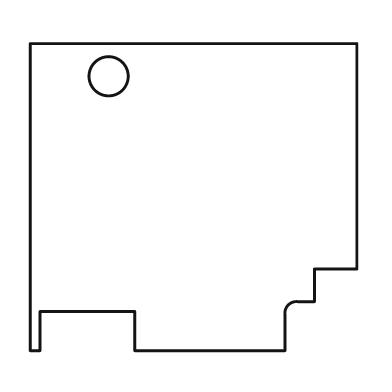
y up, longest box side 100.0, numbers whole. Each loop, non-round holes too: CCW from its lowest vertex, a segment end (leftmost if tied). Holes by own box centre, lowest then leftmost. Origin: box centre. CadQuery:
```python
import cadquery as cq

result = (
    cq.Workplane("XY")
    .moveTo(-50.0, -47.0)
    .lineTo(-47.0, -47.0)
    .lineTo(-47.0, -35.0)
    .lineTo(-18.0, -35.0)
    .lineTo(-18.0, -47.0)
    .lineTo(28.0, -47.0)
    .lineTo(28.0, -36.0)
    .threePointArc((29.0, -33.0), (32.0, -32.0))
    .lineTo(37.0, -32.0)
    .lineTo(37.0, -22.0)
    .lineTo(50.0, -22.0)
    .lineTo(50.0, 47.0)
    .lineTo(-50.0, 47.0)
    .close()
    .moveTo(-26.0, 37.0)
    .circle(6.0)
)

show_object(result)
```